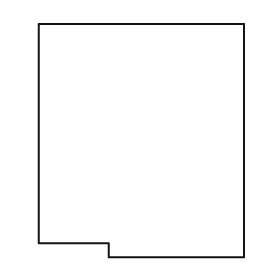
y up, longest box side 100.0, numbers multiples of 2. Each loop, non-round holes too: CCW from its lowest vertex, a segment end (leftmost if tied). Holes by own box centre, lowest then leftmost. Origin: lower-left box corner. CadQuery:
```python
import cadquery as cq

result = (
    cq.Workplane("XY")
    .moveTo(30.0, 0.0)
    .lineTo(88.0, 0.0)
    .lineTo(88.0, 100.0)
    .lineTo(0.0, 100.0)
    .lineTo(0.0, 6.0)
    .lineTo(30.0, 6.0)
    .close()
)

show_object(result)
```